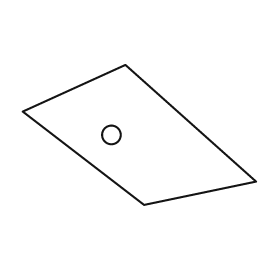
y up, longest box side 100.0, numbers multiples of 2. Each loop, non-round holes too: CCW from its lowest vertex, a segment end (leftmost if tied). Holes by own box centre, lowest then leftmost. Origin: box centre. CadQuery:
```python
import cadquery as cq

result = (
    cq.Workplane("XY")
    .moveTo(2.0, -30.0)
    .lineTo(50.0, -20.0)
    .lineTo(-6.0, 30.0)
    .lineTo(-50.0, 10.0)
    .close()
    .moveTo(-12.0, 0.0)
    .circle(4.0)
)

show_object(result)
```